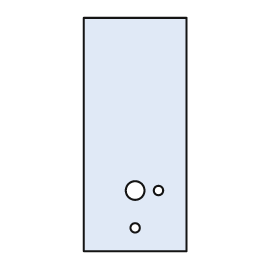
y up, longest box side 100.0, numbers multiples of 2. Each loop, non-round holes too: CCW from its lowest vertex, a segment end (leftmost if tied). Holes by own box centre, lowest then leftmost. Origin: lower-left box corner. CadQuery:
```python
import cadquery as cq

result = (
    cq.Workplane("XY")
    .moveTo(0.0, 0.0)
    .lineTo(44.0, 0.0)
    .lineTo(44.0, 100.0)
    .lineTo(0.0, 100.0)
    .close()
    .moveTo(22.0, 10.0)
    .circle(2.0)
    .moveTo(22.0, 26.0)
    .circle(4.0)
    .moveTo(32.0, 26.0)
    .circle(2.0)
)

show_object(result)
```